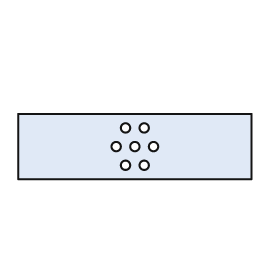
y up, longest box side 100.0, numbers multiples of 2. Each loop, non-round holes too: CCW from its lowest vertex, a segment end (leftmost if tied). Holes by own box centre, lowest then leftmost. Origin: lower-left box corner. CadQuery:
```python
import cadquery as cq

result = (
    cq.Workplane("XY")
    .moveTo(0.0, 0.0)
    .lineTo(100.0, 0.0)
    .lineTo(100.0, 28.0)
    .lineTo(0.0, 28.0)
    .close()
    .moveTo(46.0, 6.0)
    .circle(2.0)
    .moveTo(54.0, 6.0)
    .circle(2.0)
    .moveTo(42.0, 14.0)
    .circle(2.0)
    .moveTo(50.0, 14.0)
    .circle(2.0)
    .moveTo(58.0, 14.0)
    .circle(2.0)
    .moveTo(46.0, 22.0)
    .circle(2.0)
    .moveTo(54.0, 22.0)
    .circle(2.0)
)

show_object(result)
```